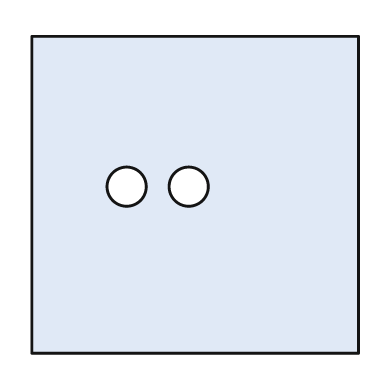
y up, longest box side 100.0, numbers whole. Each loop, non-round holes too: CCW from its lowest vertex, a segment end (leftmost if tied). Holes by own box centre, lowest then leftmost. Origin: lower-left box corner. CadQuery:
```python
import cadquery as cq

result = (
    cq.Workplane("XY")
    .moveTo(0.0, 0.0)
    .lineTo(100.0, 0.0)
    .lineTo(100.0, 97.0)
    .lineTo(0.0, 97.0)
    .close()
    .moveTo(29.0, 51.0)
    .circle(6.0)
    .moveTo(48.0, 51.0)
    .circle(6.0)
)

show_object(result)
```